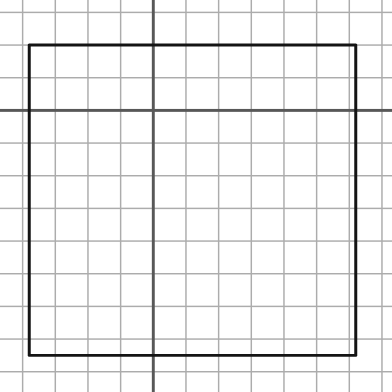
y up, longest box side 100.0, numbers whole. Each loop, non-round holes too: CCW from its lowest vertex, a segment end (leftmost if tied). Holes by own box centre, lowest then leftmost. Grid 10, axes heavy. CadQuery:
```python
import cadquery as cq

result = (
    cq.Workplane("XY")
    .moveTo(-38.0, -75.0)
    .lineTo(62.0, -75.0)
    .lineTo(62.0, 20.0)
    .lineTo(-38.0, 20.0)
    .close()
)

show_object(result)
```